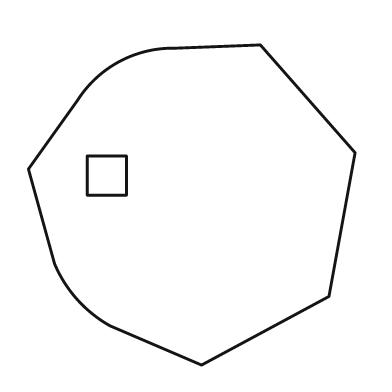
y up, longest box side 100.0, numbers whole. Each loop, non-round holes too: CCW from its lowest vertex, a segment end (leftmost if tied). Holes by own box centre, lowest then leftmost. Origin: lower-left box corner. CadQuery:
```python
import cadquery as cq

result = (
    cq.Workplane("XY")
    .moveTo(53.0, 0.0)
    .lineTo(92.0, 21.0)
    .lineTo(100.0, 65.0)
    .lineTo(71.0, 98.0)
    .lineTo(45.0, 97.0)
    .threePointArc((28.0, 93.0), (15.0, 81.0))
    .lineTo(0.0, 60.0)
    .lineTo(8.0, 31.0)
    .threePointArc((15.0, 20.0), (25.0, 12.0))
    .close()
    .moveTo(18.0, 52.0)
    .lineTo(30.0, 52.0)
    .lineTo(30.0, 64.0)
    .lineTo(18.0, 64.0)
    .close()
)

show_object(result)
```